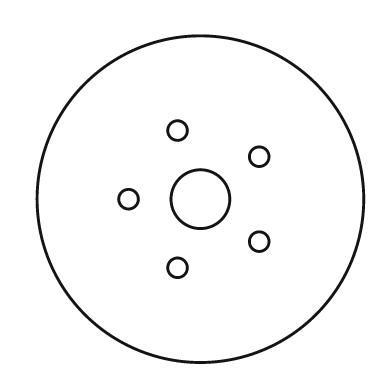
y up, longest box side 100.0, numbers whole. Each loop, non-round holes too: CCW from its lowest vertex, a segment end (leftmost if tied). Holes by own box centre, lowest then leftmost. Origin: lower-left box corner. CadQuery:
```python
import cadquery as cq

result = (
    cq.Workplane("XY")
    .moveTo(50.0, 50.0)
    .circle(50.0)
    .moveTo(43.0, 29.0)
    .circle(3.0)
    .moveTo(68.0, 37.0)
    .circle(3.0)
    .moveTo(28.0, 50.0)
    .circle(3.0)
    .moveTo(50.0, 50.0)
    .circle(9.0)
    .moveTo(68.0, 63.0)
    .circle(3.0)
    .moveTo(43.0, 71.0)
    .circle(3.0)
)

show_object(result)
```